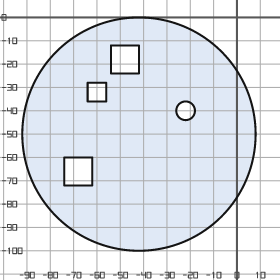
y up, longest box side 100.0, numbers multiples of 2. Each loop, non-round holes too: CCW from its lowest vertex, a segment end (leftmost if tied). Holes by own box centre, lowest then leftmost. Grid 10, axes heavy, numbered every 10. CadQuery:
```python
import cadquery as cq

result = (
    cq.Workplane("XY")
    .moveTo(-42.0, -50.0)
    .circle(50.0)
    .moveTo(-74.0, -72.0)
    .lineTo(-62.0, -72.0)
    .lineTo(-62.0, -60.0)
    .lineTo(-74.0, -60.0)
    .close()
    .moveTo(-22.0, -40.0)
    .circle(4.0)
    .moveTo(-64.0, -36.0)
    .lineTo(-56.0, -36.0)
    .lineTo(-56.0, -28.0)
    .lineTo(-64.0, -28.0)
    .close()
    .moveTo(-54.0, -24.0)
    .lineTo(-42.0, -24.0)
    .lineTo(-42.0, -12.0)
    .lineTo(-54.0, -12.0)
    .close()
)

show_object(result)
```